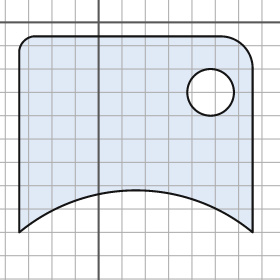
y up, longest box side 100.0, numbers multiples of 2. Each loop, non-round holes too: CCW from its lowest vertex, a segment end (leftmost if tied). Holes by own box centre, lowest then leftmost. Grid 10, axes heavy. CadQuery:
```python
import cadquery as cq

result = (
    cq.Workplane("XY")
    .moveTo(-34.0, -90.0)
    .threePointArc((16.0, -72.0), (66.0, -90.0))
    .lineTo(66.0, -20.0)
    .threePointArc((62.0, -10.0), (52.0, -6.0))
    .lineTo(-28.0, -6.0)
    .threePointArc((-32.0, -8.0), (-34.0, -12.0))
    .close()
    .moveTo(48.0, -30.0)
    .circle(10.0)
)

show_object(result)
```